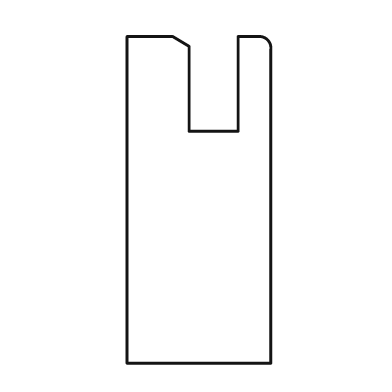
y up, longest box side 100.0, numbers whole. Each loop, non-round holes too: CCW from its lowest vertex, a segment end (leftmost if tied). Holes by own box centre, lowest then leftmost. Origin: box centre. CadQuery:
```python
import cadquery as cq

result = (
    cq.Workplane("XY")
    .moveTo(-22.0, -50.0)
    .lineTo(22.0, -50.0)
    .lineTo(22.0, 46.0)
    .threePointArc((21.0, 49.0), (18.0, 50.0))
    .lineTo(12.0, 50.0)
    .lineTo(12.0, 21.0)
    .lineTo(-3.0, 21.0)
    .lineTo(-3.0, 47.0)
    .lineTo(-8.0, 50.0)
    .lineTo(-22.0, 50.0)
    .close()
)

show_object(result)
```